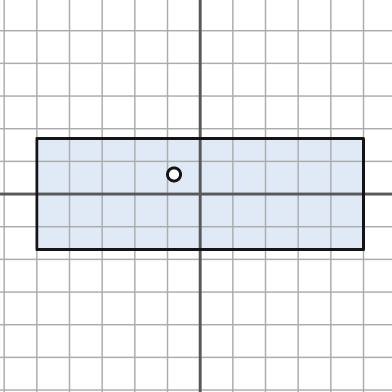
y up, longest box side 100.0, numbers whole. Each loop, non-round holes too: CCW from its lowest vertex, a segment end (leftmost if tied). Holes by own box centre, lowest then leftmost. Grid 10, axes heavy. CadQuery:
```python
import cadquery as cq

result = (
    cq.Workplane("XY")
    .moveTo(-50.0, -17.0)
    .lineTo(50.0, -17.0)
    .lineTo(50.0, 17.0)
    .lineTo(-50.0, 17.0)
    .close()
    .moveTo(-8.0, 6.0)
    .circle(2.0)
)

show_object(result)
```